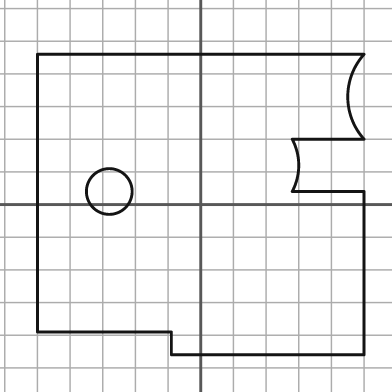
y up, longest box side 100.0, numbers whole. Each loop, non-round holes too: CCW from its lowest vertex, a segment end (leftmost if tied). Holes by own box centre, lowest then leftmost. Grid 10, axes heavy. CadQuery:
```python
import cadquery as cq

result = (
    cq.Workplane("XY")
    .moveTo(-9.0, -46.0)
    .lineTo(50.0, -46.0)
    .lineTo(50.0, 4.0)
    .lineTo(28.0, 4.0)
    .threePointArc((30.0, 12.0), (28.0, 20.0))
    .lineTo(50.0, 20.0)
    .threePointArc((45.0, 33.0), (50.0, 46.0))
    .lineTo(-50.0, 46.0)
    .lineTo(-50.0, -39.0)
    .lineTo(-9.0, -39.0)
    .close()
    .moveTo(-28.0, 4.0)
    .circle(7.0)
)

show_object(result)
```